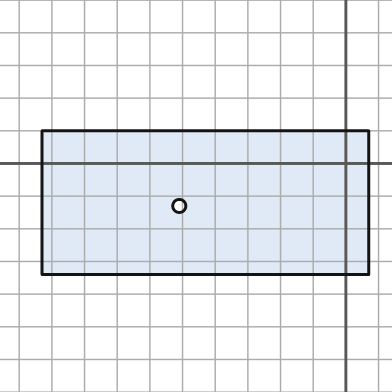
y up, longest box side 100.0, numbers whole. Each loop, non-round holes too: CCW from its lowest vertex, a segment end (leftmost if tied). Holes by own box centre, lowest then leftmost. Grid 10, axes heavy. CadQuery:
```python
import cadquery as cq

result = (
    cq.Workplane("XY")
    .moveTo(-93.0, -34.0)
    .lineTo(7.0, -34.0)
    .lineTo(7.0, 10.0)
    .lineTo(-93.0, 10.0)
    .close()
    .moveTo(-51.0, -13.0)
    .circle(2.0)
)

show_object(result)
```